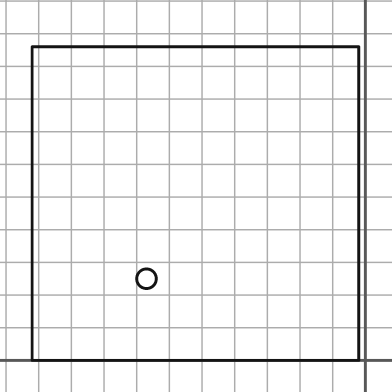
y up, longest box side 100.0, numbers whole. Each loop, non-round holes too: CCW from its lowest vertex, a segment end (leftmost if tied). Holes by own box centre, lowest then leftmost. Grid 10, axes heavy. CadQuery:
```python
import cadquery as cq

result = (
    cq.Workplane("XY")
    .moveTo(-102.0, 0.0)
    .lineTo(-2.0, 0.0)
    .lineTo(-2.0, 96.0)
    .lineTo(-102.0, 96.0)
    .close()
    .moveTo(-67.0, 25.0)
    .circle(3.0)
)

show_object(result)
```